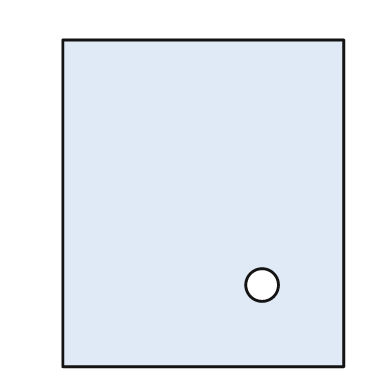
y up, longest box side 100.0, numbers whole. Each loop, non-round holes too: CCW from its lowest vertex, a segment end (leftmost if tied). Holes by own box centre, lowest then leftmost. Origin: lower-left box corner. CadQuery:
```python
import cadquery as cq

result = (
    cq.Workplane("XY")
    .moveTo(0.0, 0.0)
    .lineTo(86.0, 0.0)
    .lineTo(86.0, 100.0)
    .lineTo(0.0, 100.0)
    .close()
    .moveTo(61.0, 25.0)
    .circle(5.0)
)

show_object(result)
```